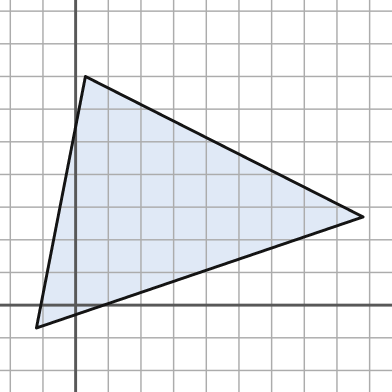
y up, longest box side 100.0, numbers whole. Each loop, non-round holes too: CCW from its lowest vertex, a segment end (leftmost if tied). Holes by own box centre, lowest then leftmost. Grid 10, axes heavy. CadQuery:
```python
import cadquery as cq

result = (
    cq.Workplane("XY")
    .moveTo(-12.0, -7.0)
    .lineTo(88.0, 27.0)
    .lineTo(3.0, 70.0)
    .close()
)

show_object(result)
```